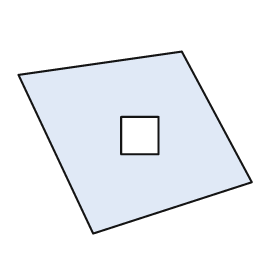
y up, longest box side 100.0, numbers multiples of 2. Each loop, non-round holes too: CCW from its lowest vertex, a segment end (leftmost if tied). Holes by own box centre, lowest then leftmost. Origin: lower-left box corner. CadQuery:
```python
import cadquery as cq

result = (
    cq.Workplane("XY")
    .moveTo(32.0, 0.0)
    .lineTo(100.0, 22.0)
    .lineTo(70.0, 78.0)
    .lineTo(0.0, 68.0)
    .close()
    .moveTo(44.0, 34.0)
    .lineTo(60.0, 34.0)
    .lineTo(60.0, 50.0)
    .lineTo(44.0, 50.0)
    .close()
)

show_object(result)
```